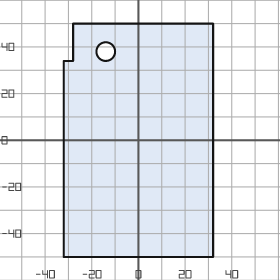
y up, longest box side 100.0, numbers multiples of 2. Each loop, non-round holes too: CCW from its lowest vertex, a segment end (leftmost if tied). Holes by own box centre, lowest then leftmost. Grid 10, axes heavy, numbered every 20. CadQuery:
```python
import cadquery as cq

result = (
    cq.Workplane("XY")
    .moveTo(-32.0, -50.0)
    .lineTo(32.0, -50.0)
    .lineTo(32.0, 50.0)
    .lineTo(-28.0, 50.0)
    .lineTo(-28.0, 34.0)
    .lineTo(-32.0, 34.0)
    .close()
    .moveTo(-14.0, 38.0)
    .circle(4.0)
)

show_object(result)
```